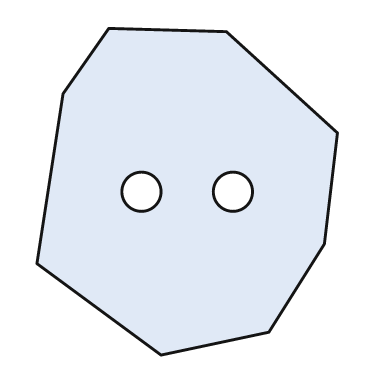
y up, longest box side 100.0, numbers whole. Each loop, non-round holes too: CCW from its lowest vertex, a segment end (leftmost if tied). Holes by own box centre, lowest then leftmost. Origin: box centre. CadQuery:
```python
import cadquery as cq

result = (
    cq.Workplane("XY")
    .moveTo(-8.0, -50.0)
    .lineTo(25.0, -43.0)
    .lineTo(42.0, -16.0)
    .lineTo(46.0, 18.0)
    .lineTo(12.0, 49.0)
    .lineTo(-24.0, 50.0)
    .lineTo(-38.0, 30.0)
    .lineTo(-46.0, -22.0)
    .close()
    .moveTo(-14.0, 0.0)
    .circle(6.0)
    .moveTo(14.0, 0.0)
    .circle(6.0)
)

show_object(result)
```